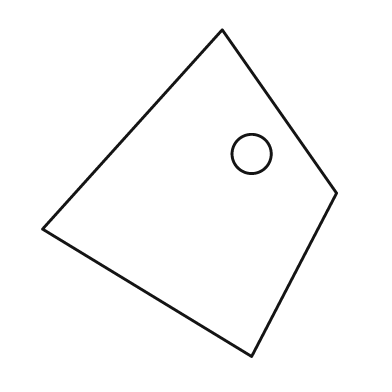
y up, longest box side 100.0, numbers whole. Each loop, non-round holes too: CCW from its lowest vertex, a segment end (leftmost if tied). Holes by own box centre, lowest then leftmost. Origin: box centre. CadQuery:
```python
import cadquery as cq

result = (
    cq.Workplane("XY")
    .moveTo(19.0, -50.0)
    .lineTo(45.0, 0.0)
    .lineTo(10.0, 50.0)
    .lineTo(-45.0, -11.0)
    .close()
    .moveTo(19.0, 12.0)
    .circle(6.0)
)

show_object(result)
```